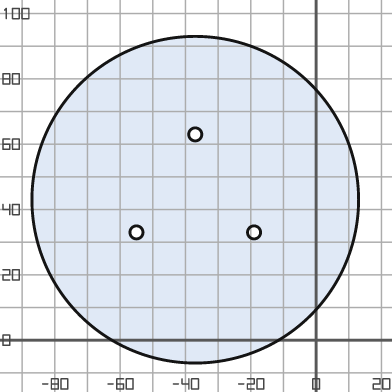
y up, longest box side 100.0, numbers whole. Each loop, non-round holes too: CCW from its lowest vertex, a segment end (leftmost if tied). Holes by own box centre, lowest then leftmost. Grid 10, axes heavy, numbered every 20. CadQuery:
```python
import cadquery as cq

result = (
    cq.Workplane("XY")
    .moveTo(-37.0, 43.0)
    .circle(50.0)
    .moveTo(-55.0, 33.0)
    .circle(2.0)
    .moveTo(-19.0, 33.0)
    .circle(2.0)
    .moveTo(-37.0, 63.0)
    .circle(2.0)
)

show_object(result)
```